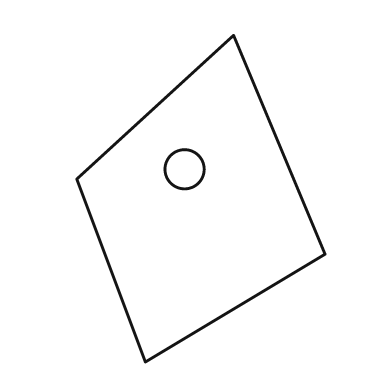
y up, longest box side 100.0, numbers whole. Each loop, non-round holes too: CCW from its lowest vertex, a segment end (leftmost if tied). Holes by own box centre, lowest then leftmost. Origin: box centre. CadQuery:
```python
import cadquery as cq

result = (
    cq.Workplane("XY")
    .moveTo(-17.0, -50.0)
    .lineTo(38.0, -17.0)
    .lineTo(10.0, 50.0)
    .lineTo(-38.0, 6.0)
    .close()
    .moveTo(-5.0, 9.0)
    .circle(6.0)
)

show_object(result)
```